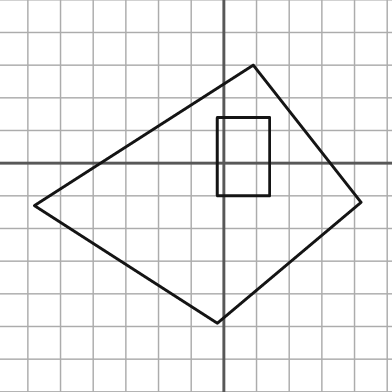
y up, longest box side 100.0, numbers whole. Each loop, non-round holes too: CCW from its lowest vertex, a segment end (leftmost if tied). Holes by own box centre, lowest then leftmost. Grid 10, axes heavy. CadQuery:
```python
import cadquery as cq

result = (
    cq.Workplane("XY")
    .moveTo(-2.0, -49.0)
    .lineTo(42.0, -12.0)
    .lineTo(9.0, 30.0)
    .lineTo(-58.0, -13.0)
    .close()
    .moveTo(-2.0, -10.0)
    .lineTo(14.0, -10.0)
    .lineTo(14.0, 14.0)
    .lineTo(-2.0, 14.0)
    .close()
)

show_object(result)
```